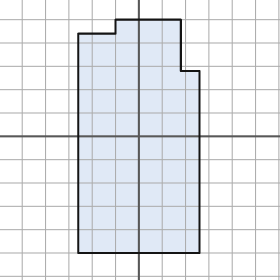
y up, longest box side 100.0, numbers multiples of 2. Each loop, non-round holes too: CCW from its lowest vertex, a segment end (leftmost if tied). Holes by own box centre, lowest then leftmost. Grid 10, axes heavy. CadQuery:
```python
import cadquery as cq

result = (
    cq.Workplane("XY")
    .moveTo(-26.0, -50.0)
    .lineTo(26.0, -50.0)
    .lineTo(26.0, 28.0)
    .lineTo(18.0, 28.0)
    .lineTo(18.0, 50.0)
    .lineTo(-10.0, 50.0)
    .lineTo(-10.0, 44.0)
    .lineTo(-26.0, 44.0)
    .close()
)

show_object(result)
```